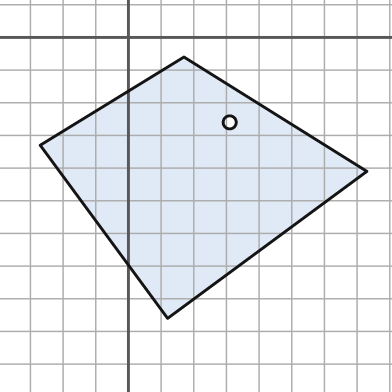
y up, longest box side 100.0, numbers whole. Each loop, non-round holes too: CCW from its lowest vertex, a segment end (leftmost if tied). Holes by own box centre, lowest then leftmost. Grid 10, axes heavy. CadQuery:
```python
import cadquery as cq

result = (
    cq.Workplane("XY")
    .moveTo(12.0, -86.0)
    .lineTo(73.0, -41.0)
    .lineTo(17.0, -6.0)
    .lineTo(-27.0, -33.0)
    .close()
    .moveTo(31.0, -26.0)
    .circle(2.0)
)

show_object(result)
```